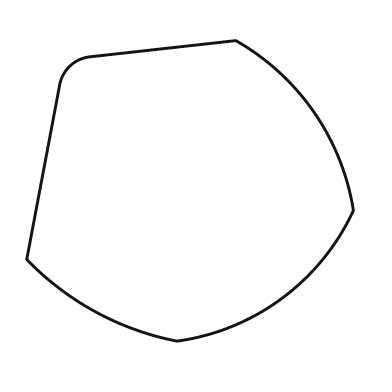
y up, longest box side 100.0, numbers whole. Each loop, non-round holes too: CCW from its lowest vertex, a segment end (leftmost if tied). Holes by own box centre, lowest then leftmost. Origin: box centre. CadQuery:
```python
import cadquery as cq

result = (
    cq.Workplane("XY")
    .moveTo(-4.0, -46.0)
    .threePointArc((28.0, -33.0), (50.0, -6.0))
    .threePointArc((38.0, 24.0), (14.0, 46.0))
    .lineTo(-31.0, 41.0)
    .threePointArc((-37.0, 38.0), (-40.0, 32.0))
    .lineTo(-50.0, -21.0)
    .threePointArc((-29.0, -37.0), (-4.0, -46.0))
    .close()
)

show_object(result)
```